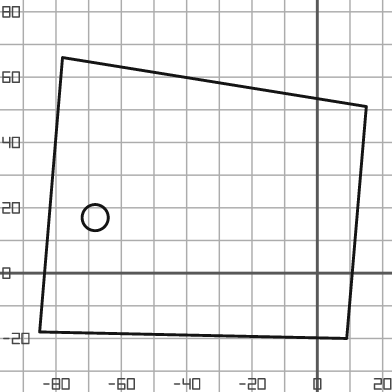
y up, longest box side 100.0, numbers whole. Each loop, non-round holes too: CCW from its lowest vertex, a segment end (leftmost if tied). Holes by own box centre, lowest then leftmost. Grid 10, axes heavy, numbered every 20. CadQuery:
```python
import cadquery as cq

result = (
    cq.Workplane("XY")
    .moveTo(9.0, -20.0)
    .lineTo(15.0, 51.0)
    .lineTo(-78.0, 66.0)
    .lineTo(-85.0, -18.0)
    .close()
    .moveTo(-68.0, 17.0)
    .circle(4.0)
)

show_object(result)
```